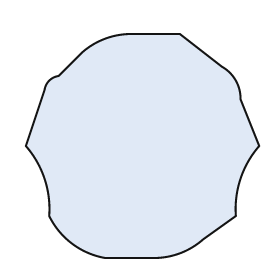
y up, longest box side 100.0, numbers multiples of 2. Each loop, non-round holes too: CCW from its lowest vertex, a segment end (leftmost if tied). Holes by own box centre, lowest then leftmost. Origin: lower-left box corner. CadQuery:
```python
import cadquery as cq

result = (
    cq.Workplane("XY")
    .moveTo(34.0, 0.0)
    .lineTo(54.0, 0.0)
    .threePointArc((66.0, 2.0), (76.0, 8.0))
    .lineTo(90.0, 18.0)
    .threePointArc((92.0, 34.0), (100.0, 48.0))
    .lineTo(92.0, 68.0)
    .threePointArc((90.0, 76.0), (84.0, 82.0))
    .lineTo(66.0, 96.0)
    .lineTo(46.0, 96.0)
    .threePointArc((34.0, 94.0), (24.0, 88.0))
    .lineTo(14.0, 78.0)
    .threePointArc((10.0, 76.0), (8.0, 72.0))
    .lineTo(0.0, 48.0)
    .threePointArc((8.0, 34.0), (10.0, 18.0))
    .threePointArc((20.0, 6.0), (34.0, 0.0))
    .close()
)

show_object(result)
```